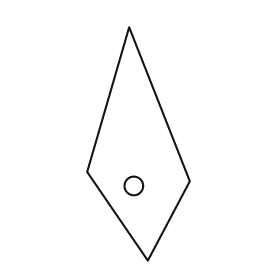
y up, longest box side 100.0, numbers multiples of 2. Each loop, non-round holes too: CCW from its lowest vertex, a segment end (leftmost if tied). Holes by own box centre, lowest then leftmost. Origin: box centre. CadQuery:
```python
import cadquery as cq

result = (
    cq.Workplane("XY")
    .moveTo(4.0, -50.0)
    .lineTo(22.0, -16.0)
    .lineTo(-4.0, 50.0)
    .lineTo(-22.0, -12.0)
    .close()
    .moveTo(-2.0, -18.0)
    .circle(4.0)
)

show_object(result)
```